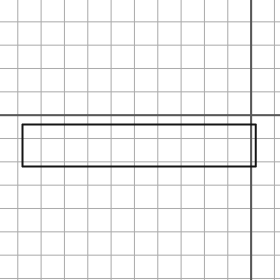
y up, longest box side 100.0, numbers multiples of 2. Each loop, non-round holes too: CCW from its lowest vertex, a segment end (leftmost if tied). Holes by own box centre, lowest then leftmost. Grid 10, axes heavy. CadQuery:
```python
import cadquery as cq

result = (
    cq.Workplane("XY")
    .moveTo(-98.0, -22.0)
    .lineTo(2.0, -22.0)
    .lineTo(2.0, -4.0)
    .lineTo(-98.0, -4.0)
    .close()
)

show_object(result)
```